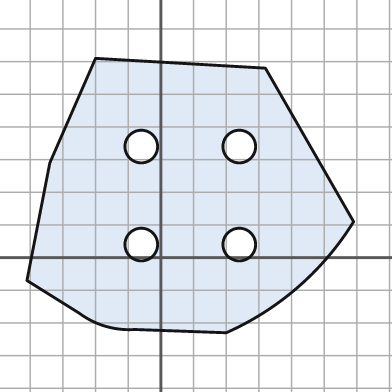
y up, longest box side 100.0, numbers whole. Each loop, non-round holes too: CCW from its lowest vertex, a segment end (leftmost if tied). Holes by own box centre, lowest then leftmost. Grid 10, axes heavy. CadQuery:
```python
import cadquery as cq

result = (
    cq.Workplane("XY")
    .moveTo(20.0, -23.0)
    .threePointArc((42.0, -9.0), (59.0, 11.0))
    .lineTo(32.0, 58.0)
    .lineTo(-20.0, 61.0)
    .lineTo(-34.0, 29.0)
    .lineTo(-41.0, -7.0)
    .lineTo(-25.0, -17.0)
    .threePointArc((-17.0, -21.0), (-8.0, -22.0))
    .close()
    .moveTo(-6.0, 4.0)
    .circle(5.0)
    .moveTo(24.0, 4.0)
    .circle(5.0)
    .moveTo(-6.0, 34.0)
    .circle(5.0)
    .moveTo(24.0, 34.0)
    .circle(5.0)
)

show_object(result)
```